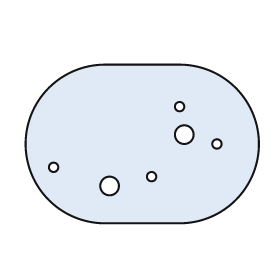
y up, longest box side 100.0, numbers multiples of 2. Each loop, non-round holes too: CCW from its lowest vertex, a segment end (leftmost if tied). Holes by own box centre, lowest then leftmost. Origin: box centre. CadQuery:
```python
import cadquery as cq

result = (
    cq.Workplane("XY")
    .moveTo(-16.0, -34.0)
    .lineTo(16.0, -34.0)
    .threePointArc((50.0, 0.0), (16.0, 34.0))
    .lineTo(-16.0, 34.0)
    .threePointArc((-50.0, 0.0), (-16.0, -34.0))
    .close()
    .moveTo(-14.0, -18.0)
    .circle(4.0)
    .moveTo(4.0, -14.0)
    .circle(2.0)
    .moveTo(-38.0, -10.0)
    .circle(2.0)
    .moveTo(32.0, 0.0)
    .circle(2.0)
    .moveTo(18.0, 4.0)
    .circle(4.0)
    .moveTo(16.0, 16.0)
    .circle(2.0)
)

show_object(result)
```